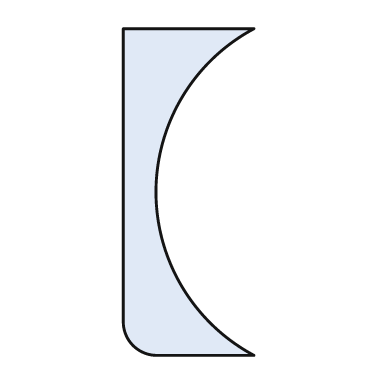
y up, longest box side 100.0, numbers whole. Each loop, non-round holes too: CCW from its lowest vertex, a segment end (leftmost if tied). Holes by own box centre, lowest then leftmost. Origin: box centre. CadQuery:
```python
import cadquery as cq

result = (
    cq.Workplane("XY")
    .moveTo(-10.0, -50.0)
    .lineTo(20.0, -50.0)
    .threePointArc((-10.0, 0.0), (20.0, 50.0))
    .lineTo(-20.0, 50.0)
    .lineTo(-20.0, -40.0)
    .threePointArc((-17.0, -47.0), (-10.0, -50.0))
    .close()
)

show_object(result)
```